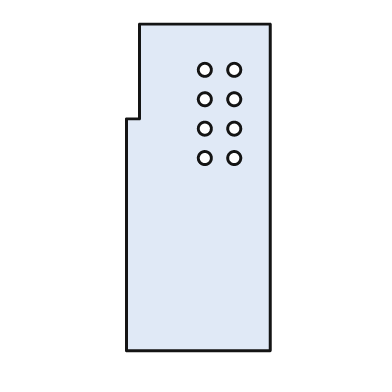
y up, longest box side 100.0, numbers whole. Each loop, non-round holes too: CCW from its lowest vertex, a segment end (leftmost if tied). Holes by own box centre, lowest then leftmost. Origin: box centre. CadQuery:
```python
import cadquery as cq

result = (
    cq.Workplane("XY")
    .moveTo(-22.0, -50.0)
    .lineTo(22.0, -50.0)
    .lineTo(22.0, 50.0)
    .lineTo(-18.0, 50.0)
    .lineTo(-18.0, 21.0)
    .lineTo(-22.0, 21.0)
    .close()
    .moveTo(2.0, 9.0)
    .circle(2.0)
    .moveTo(11.0, 9.0)
    .circle(2.0)
    .moveTo(2.0, 18.0)
    .circle(2.0)
    .moveTo(11.0, 18.0)
    .circle(2.0)
    .moveTo(2.0, 27.0)
    .circle(2.0)
    .moveTo(11.0, 27.0)
    .circle(2.0)
    .moveTo(2.0, 36.0)
    .circle(2.0)
    .moveTo(11.0, 36.0)
    .circle(2.0)
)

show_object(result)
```